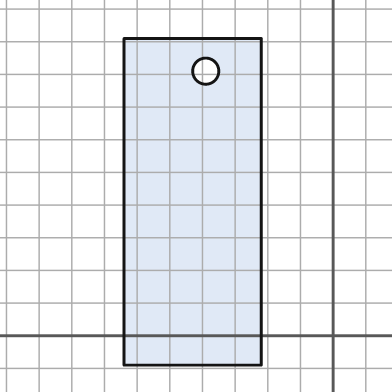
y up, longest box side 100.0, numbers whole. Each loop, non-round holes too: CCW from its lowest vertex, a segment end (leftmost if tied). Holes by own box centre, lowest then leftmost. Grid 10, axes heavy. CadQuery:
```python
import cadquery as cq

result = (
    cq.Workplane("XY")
    .moveTo(-64.0, -9.0)
    .lineTo(-22.0, -9.0)
    .lineTo(-22.0, 91.0)
    .lineTo(-64.0, 91.0)
    .close()
    .moveTo(-39.0, 81.0)
    .circle(4.0)
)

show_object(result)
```